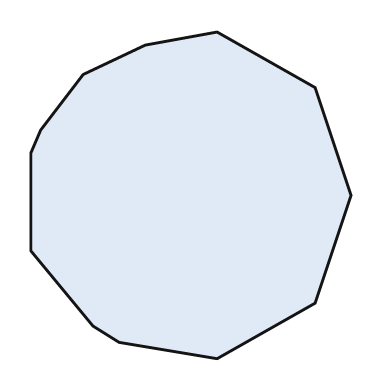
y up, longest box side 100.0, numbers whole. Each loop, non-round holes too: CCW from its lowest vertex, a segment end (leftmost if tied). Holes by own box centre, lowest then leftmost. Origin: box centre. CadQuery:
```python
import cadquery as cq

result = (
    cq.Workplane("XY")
    .moveTo(8.0, -50.0)
    .lineTo(38.0, -33.0)
    .lineTo(49.0, 0.0)
    .lineTo(38.0, 33.0)
    .lineTo(8.0, 50.0)
    .lineTo(-14.0, 46.0)
    .lineTo(-33.0, 37.0)
    .lineTo(-46.0, 20.0)
    .lineTo(-49.0, 13.0)
    .lineTo(-49.0, -17.0)
    .lineTo(-30.0, -40.0)
    .lineTo(-22.0, -45.0)
    .close()
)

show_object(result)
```